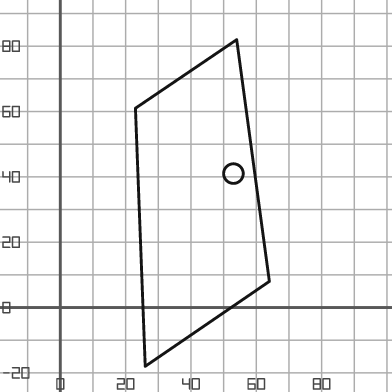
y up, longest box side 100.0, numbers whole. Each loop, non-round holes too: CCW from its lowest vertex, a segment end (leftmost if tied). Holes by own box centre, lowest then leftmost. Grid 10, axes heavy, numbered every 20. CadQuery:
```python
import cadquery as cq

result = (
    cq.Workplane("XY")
    .moveTo(26.0, -18.0)
    .lineTo(64.0, 8.0)
    .lineTo(54.0, 82.0)
    .lineTo(23.0, 61.0)
    .close()
    .moveTo(53.0, 41.0)
    .circle(3.0)
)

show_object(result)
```